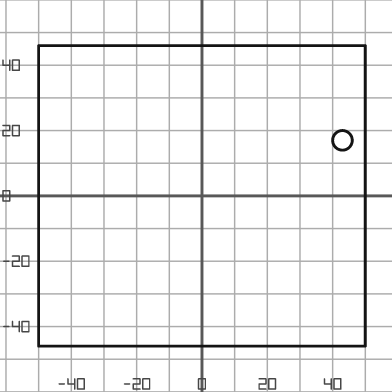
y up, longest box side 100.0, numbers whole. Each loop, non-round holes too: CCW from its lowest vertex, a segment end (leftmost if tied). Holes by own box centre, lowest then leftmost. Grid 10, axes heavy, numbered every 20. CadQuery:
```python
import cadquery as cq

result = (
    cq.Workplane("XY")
    .moveTo(-50.0, -46.0)
    .lineTo(50.0, -46.0)
    .lineTo(50.0, 46.0)
    .lineTo(-50.0, 46.0)
    .close()
    .moveTo(43.0, 17.0)
    .circle(3.0)
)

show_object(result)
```